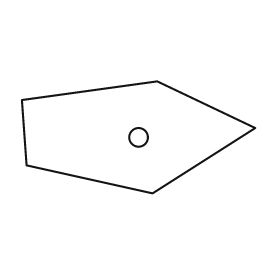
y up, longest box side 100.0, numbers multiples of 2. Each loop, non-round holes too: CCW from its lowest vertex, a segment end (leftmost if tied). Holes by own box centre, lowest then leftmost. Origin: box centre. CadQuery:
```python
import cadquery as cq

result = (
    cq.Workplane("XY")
    .moveTo(6.0, -24.0)
    .lineTo(50.0, 4.0)
    .lineTo(8.0, 24.0)
    .lineTo(-50.0, 16.0)
    .lineTo(-48.0, -12.0)
    .close()
    .moveTo(0.0, 0.0)
    .circle(4.0)
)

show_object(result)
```